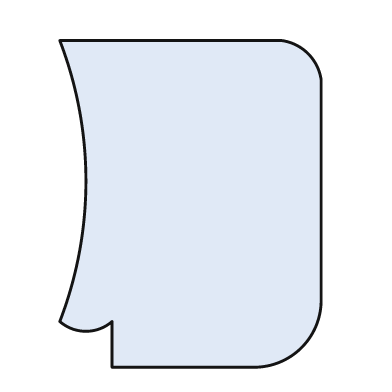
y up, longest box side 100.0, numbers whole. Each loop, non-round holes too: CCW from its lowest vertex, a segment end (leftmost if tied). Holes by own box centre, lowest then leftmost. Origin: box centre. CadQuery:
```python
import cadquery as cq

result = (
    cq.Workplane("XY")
    .moveTo(-24.0, -50.0)
    .lineTo(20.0, -50.0)
    .threePointArc((34.0, -44.0), (40.0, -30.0))
    .lineTo(40.0, 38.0)
    .threePointArc((36.0, 46.0), (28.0, 50.0))
    .lineTo(-40.0, 50.0)
    .threePointArc((-32.0, 7.0), (-40.0, -36.0))
    .threePointArc((-32.0, -39.0), (-24.0, -36.0))
    .close()
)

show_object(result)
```